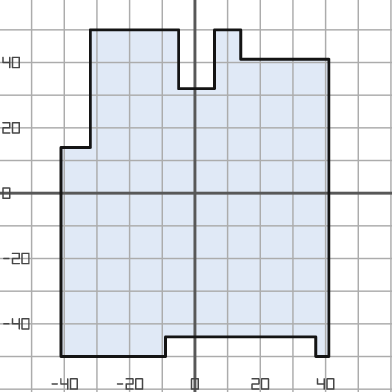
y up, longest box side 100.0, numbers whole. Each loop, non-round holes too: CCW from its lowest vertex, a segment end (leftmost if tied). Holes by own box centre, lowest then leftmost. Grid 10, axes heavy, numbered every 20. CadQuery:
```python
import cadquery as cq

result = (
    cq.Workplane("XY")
    .moveTo(-41.0, -50.0)
    .lineTo(-9.0, -50.0)
    .lineTo(-9.0, -44.0)
    .lineTo(37.0, -44.0)
    .lineTo(37.0, -50.0)
    .lineTo(41.0, -50.0)
    .lineTo(41.0, 41.0)
    .lineTo(14.0, 41.0)
    .lineTo(14.0, 50.0)
    .lineTo(6.0, 50.0)
    .lineTo(6.0, 32.0)
    .lineTo(-5.0, 32.0)
    .lineTo(-5.0, 50.0)
    .lineTo(-32.0, 50.0)
    .lineTo(-32.0, 14.0)
    .lineTo(-41.0, 14.0)
    .close()
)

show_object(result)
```